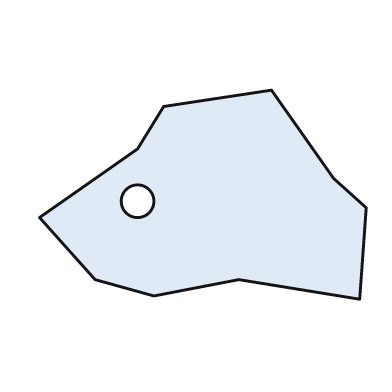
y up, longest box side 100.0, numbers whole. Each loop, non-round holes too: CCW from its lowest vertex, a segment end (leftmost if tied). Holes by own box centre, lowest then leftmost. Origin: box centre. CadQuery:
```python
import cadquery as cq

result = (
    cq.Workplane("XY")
    .moveTo(48.0, -32.0)
    .lineTo(50.0, -4.0)
    .lineTo(40.0, 5.0)
    .lineTo(21.0, 32.0)
    .lineTo(-12.0, 27.0)
    .lineTo(-20.0, 14.0)
    .lineTo(-50.0, -7.0)
    .lineTo(-33.0, -26.0)
    .lineTo(-15.0, -31.0)
    .lineTo(11.0, -26.0)
    .close()
    .moveTo(-20.0, -2.0)
    .circle(5.0)
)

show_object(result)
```